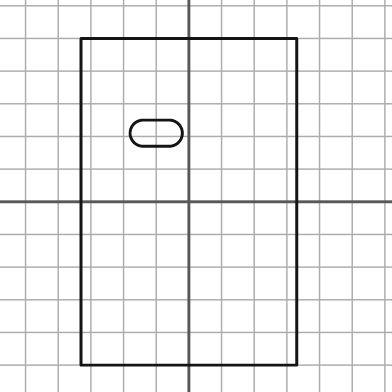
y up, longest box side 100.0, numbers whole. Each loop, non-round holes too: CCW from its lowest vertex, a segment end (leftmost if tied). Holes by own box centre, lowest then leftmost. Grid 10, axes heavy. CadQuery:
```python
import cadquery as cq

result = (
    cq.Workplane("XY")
    .moveTo(-33.0, -50.0)
    .lineTo(33.0, -50.0)
    .lineTo(33.0, 50.0)
    .lineTo(-33.0, 50.0)
    .close()
    .moveTo(-14.0, 17.0)
    .lineTo(-6.0, 17.0)
    .threePointArc((-2.0, 21.0), (-6.0, 25.0))
    .lineTo(-14.0, 25.0)
    .threePointArc((-18.0, 21.0), (-14.0, 17.0))
    .close()
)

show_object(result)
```